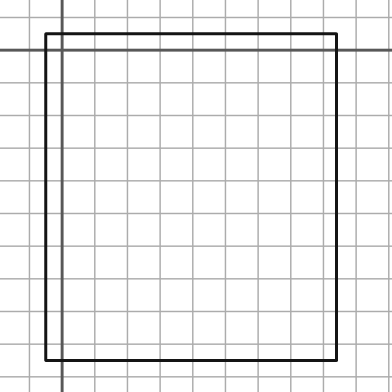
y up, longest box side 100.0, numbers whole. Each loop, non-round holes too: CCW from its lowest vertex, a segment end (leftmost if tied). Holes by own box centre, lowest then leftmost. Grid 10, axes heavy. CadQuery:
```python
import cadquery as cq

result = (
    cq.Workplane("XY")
    .moveTo(-5.0, -95.0)
    .lineTo(84.0, -95.0)
    .lineTo(84.0, 5.0)
    .lineTo(-5.0, 5.0)
    .close()
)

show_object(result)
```